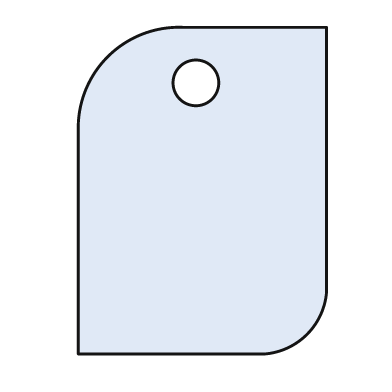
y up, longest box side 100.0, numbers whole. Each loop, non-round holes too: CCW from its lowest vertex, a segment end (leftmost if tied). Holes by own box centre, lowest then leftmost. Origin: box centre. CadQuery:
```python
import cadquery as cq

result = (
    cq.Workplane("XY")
    .moveTo(-38.0, -50.0)
    .lineTo(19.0, -50.0)
    .threePointArc((32.0, -44.0), (38.0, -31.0))
    .lineTo(38.0, 50.0)
    .lineTo(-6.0, 50.0)
    .threePointArc((-29.0, 41.0), (-38.0, 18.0))
    .close()
    .moveTo(-2.0, 33.0)
    .circle(7.0)
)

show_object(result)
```